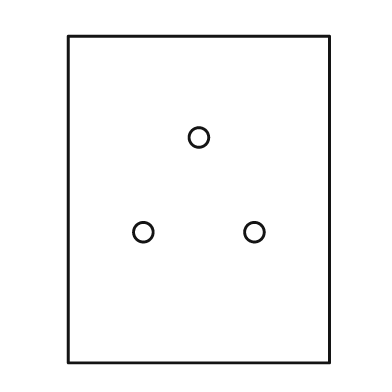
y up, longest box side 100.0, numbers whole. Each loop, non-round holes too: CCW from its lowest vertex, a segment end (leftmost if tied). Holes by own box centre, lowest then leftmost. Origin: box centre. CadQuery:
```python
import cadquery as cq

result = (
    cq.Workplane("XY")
    .moveTo(-40.0, -50.0)
    .lineTo(40.0, -50.0)
    .lineTo(40.0, 50.0)
    .lineTo(-40.0, 50.0)
    .close()
    .moveTo(-17.0, -10.0)
    .circle(3.0)
    .moveTo(17.0, -10.0)
    .circle(3.0)
    .moveTo(0.0, 19.0)
    .circle(3.0)
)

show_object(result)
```